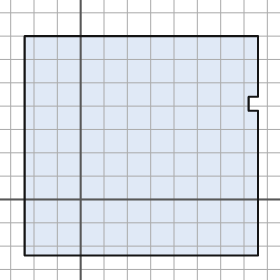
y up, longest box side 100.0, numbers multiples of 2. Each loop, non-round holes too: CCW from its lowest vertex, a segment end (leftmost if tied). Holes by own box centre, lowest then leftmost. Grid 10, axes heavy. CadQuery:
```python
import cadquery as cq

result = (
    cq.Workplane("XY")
    .moveTo(-24.0, -24.0)
    .lineTo(76.0, -24.0)
    .lineTo(76.0, 38.0)
    .lineTo(72.0, 38.0)
    .lineTo(72.0, 44.0)
    .lineTo(76.0, 44.0)
    .lineTo(76.0, 70.0)
    .lineTo(-24.0, 70.0)
    .close()
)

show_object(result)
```